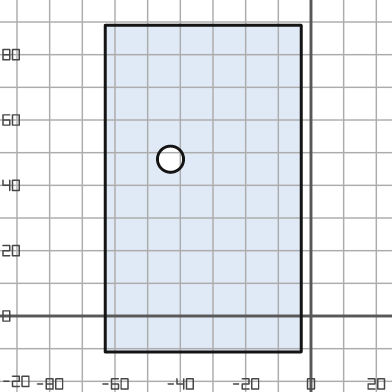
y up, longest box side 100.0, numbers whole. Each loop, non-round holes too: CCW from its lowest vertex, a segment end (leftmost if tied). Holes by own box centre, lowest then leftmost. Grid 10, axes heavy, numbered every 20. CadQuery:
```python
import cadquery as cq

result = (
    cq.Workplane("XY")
    .moveTo(-63.0, -11.0)
    .lineTo(-3.0, -11.0)
    .lineTo(-3.0, 89.0)
    .lineTo(-63.0, 89.0)
    .close()
    .moveTo(-43.0, 48.0)
    .circle(4.0)
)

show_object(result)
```